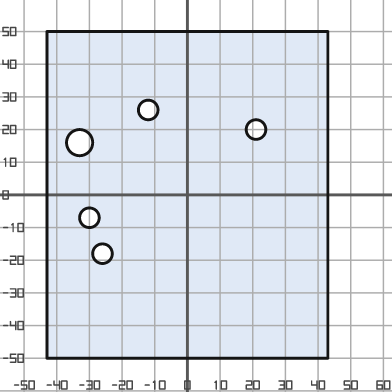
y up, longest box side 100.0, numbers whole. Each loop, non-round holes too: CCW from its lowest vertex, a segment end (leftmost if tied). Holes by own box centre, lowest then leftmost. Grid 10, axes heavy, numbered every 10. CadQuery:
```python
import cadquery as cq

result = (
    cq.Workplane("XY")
    .moveTo(-43.0, -50.0)
    .lineTo(43.0, -50.0)
    .lineTo(43.0, 50.0)
    .lineTo(-43.0, 50.0)
    .close()
    .moveTo(-26.0, -18.0)
    .circle(3.0)
    .moveTo(-30.0, -7.0)
    .circle(3.0)
    .moveTo(-33.0, 16.0)
    .circle(4.0)
    .moveTo(21.0, 20.0)
    .circle(3.0)
    .moveTo(-12.0, 26.0)
    .circle(3.0)
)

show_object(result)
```